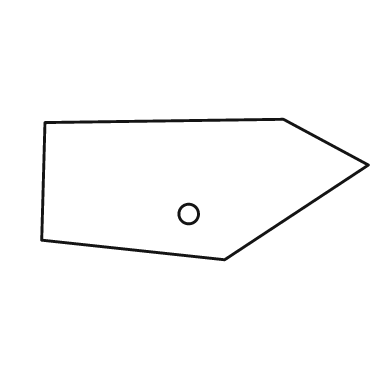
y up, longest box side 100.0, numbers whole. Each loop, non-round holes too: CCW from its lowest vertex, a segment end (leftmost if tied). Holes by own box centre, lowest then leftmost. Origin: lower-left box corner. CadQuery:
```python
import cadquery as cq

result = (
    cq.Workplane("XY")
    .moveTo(56.0, 0.0)
    .lineTo(100.0, 29.0)
    .lineTo(74.0, 43.0)
    .lineTo(1.0, 42.0)
    .lineTo(0.0, 6.0)
    .close()
    .moveTo(45.0, 14.0)
    .circle(3.0)
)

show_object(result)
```